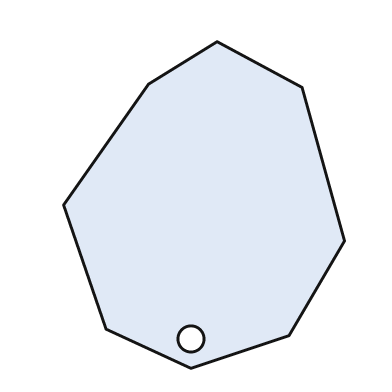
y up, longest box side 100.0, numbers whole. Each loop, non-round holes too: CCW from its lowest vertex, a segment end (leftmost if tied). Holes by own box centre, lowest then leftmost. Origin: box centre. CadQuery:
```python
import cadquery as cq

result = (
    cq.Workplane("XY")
    .moveTo(-4.0, -50.0)
    .lineTo(26.0, -40.0)
    .lineTo(43.0, -11.0)
    .lineTo(30.0, 36.0)
    .lineTo(4.0, 50.0)
    .lineTo(-17.0, 37.0)
    .lineTo(-43.0, 0.0)
    .lineTo(-30.0, -38.0)
    .close()
    .moveTo(-4.0, -41.0)
    .circle(4.0)
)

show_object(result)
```